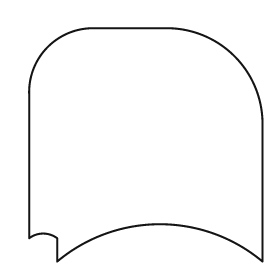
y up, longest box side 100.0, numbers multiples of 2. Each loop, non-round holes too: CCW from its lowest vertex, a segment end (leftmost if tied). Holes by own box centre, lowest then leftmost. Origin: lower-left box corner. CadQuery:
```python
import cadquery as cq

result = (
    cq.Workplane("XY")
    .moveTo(12.0, 0.0)
    .threePointArc((56.0, 16.0), (100.0, 0.0))
    .lineTo(100.0, 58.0)
    .threePointArc((88.0, 88.0), (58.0, 100.0))
    .lineTo(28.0, 100.0)
    .threePointArc((8.0, 92.0), (0.0, 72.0))
    .lineTo(0.0, 10.0)
    .threePointArc((6.0, 12.0), (12.0, 10.0))
    .close()
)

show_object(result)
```